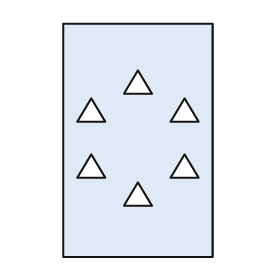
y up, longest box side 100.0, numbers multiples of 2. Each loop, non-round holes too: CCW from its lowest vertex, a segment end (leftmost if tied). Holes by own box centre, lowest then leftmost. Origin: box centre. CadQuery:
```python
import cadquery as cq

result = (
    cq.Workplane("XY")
    .moveTo(-32.0, -50.0)
    .lineTo(32.0, -50.0)
    .lineTo(32.0, 50.0)
    .lineTo(-32.0, 50.0)
    .close()
    .moveTo(-6.0, -28.0)
    .lineTo(6.0, -28.0)
    .lineTo(0.0, -18.0)
    .close()
    .moveTo(-26.0, -16.0)
    .lineTo(-14.0, -16.0)
    .lineTo(-20.0, -6.0)
    .close()
    .moveTo(14.0, -16.0)
    .lineTo(26.0, -16.0)
    .lineTo(20.0, -6.0)
    .close()
    .moveTo(-26.0, 8.0)
    .lineTo(-14.0, 8.0)
    .lineTo(-20.0, 18.0)
    .close()
    .moveTo(14.0, 8.0)
    .lineTo(26.0, 8.0)
    .lineTo(20.0, 18.0)
    .close()
    .moveTo(-6.0, 20.0)
    .lineTo(6.0, 20.0)
    .lineTo(0.0, 30.0)
    .close()
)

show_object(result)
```